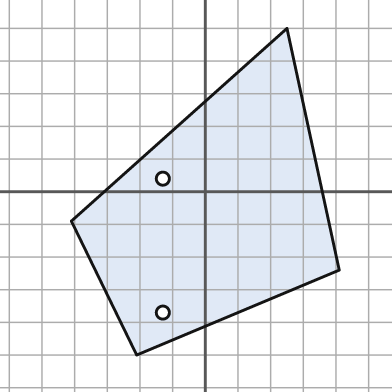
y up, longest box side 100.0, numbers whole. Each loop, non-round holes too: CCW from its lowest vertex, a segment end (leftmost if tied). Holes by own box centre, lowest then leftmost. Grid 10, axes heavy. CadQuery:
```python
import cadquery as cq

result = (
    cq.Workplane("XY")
    .moveTo(-21.0, -50.0)
    .lineTo(41.0, -24.0)
    .lineTo(25.0, 50.0)
    .lineTo(-41.0, -9.0)
    .close()
    .moveTo(-13.0, -37.0)
    .circle(2.0)
    .moveTo(-13.0, 4.0)
    .circle(2.0)
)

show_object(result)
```